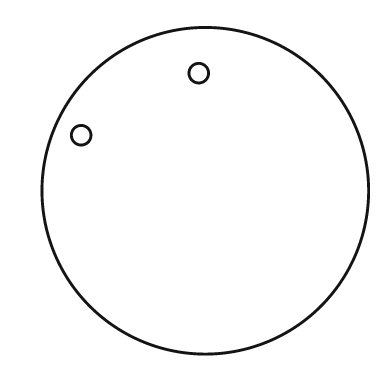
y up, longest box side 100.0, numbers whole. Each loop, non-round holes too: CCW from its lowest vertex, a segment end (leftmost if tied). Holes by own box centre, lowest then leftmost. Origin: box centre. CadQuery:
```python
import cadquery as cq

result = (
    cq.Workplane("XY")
    .moveTo(0.0, 0.0)
    .circle(50.0)
    .moveTo(-38.0, 17.0)
    .circle(3.0)
    .moveTo(-2.0, 36.0)
    .circle(3.0)
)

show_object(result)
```